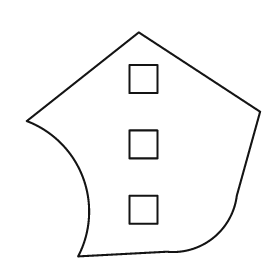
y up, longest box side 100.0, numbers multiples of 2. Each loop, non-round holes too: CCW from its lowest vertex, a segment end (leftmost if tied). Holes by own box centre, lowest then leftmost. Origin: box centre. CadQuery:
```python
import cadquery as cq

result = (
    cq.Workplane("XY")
    .moveTo(-28.0, -48.0)
    .lineTo(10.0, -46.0)
    .threePointArc((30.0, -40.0), (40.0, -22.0))
    .lineTo(50.0, 14.0)
    .lineTo(-2.0, 48.0)
    .lineTo(-50.0, 10.0)
    .threePointArc((-26.0, -14.0), (-28.0, -48.0))
    .close()
    .moveTo(-6.0, -34.0)
    .lineTo(6.0, -34.0)
    .lineTo(6.0, -22.0)
    .lineTo(-6.0, -22.0)
    .close()
    .moveTo(-6.0, -6.0)
    .lineTo(6.0, -6.0)
    .lineTo(6.0, 6.0)
    .lineTo(-6.0, 6.0)
    .close()
    .moveTo(-6.0, 22.0)
    .lineTo(6.0, 22.0)
    .lineTo(6.0, 34.0)
    .lineTo(-6.0, 34.0)
    .close()
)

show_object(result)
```